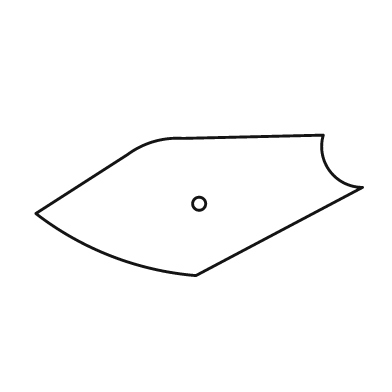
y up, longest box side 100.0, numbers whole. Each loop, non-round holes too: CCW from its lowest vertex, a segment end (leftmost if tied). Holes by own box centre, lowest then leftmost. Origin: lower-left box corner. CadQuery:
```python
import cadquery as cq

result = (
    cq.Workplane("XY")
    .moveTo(49.0, 0.0)
    .lineTo(100.0, 27.0)
    .threePointArc((90.0, 32.0), (88.0, 43.0))
    .lineTo(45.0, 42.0)
    .threePointArc((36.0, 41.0), (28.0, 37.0))
    .lineTo(0.0, 19.0)
    .threePointArc((23.0, 6.0), (49.0, 0.0))
    .close()
    .moveTo(50.0, 22.0)
    .circle(2.0)
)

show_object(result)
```